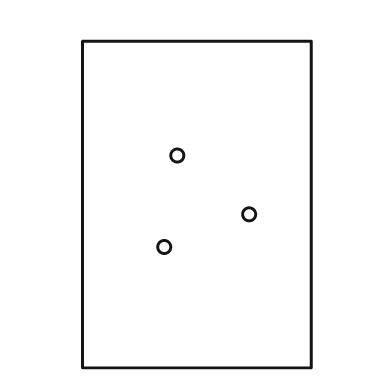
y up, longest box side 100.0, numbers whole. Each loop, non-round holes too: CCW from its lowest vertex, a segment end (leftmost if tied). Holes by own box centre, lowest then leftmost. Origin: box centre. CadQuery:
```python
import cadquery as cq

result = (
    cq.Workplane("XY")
    .moveTo(-35.0, -50.0)
    .lineTo(35.0, -50.0)
    .lineTo(35.0, 50.0)
    .lineTo(-35.0, 50.0)
    .close()
    .moveTo(-10.0, -13.0)
    .circle(2.0)
    .moveTo(16.0, -3.0)
    .circle(2.0)
    .moveTo(-6.0, 15.0)
    .circle(2.0)
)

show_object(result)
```